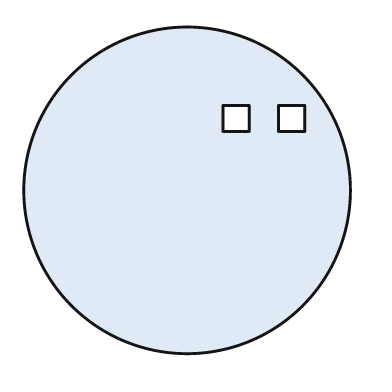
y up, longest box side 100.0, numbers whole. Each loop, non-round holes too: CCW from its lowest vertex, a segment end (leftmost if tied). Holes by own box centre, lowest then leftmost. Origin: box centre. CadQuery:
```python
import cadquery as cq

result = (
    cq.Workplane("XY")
    .moveTo(0.0, 0.0)
    .circle(50.0)
    .moveTo(11.0, 18.0)
    .lineTo(19.0, 18.0)
    .lineTo(19.0, 26.0)
    .lineTo(11.0, 26.0)
    .close()
    .moveTo(28.0, 18.0)
    .lineTo(36.0, 18.0)
    .lineTo(36.0, 26.0)
    .lineTo(28.0, 26.0)
    .close()
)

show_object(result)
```